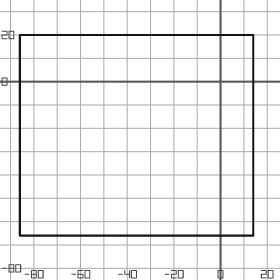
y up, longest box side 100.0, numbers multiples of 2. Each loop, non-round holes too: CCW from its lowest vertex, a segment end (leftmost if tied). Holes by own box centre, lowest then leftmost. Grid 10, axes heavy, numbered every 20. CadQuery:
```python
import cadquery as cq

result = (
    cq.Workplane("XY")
    .moveTo(-86.0, -66.0)
    .lineTo(14.0, -66.0)
    .lineTo(14.0, 20.0)
    .lineTo(-86.0, 20.0)
    .close()
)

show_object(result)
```